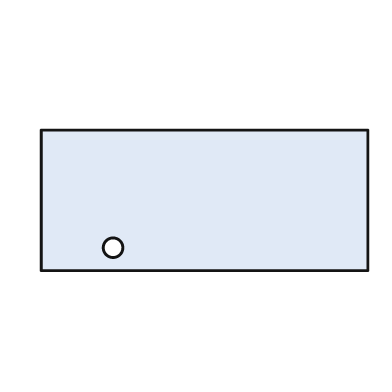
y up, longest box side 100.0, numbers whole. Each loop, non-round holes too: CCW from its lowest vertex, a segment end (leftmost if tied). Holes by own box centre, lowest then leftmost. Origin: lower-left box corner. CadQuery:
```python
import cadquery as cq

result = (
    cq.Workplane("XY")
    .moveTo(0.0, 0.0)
    .lineTo(100.0, 0.0)
    .lineTo(100.0, 43.0)
    .lineTo(0.0, 43.0)
    .close()
    .moveTo(22.0, 7.0)
    .circle(3.0)
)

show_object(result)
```